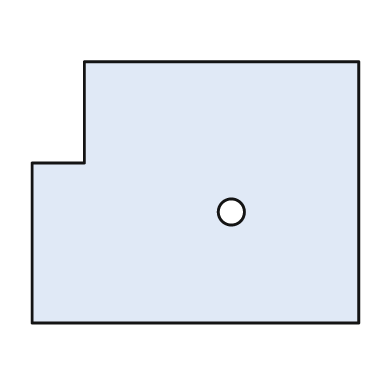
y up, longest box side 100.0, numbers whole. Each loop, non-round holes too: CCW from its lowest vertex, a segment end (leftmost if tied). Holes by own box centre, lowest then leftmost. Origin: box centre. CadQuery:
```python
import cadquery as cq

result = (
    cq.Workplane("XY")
    .moveTo(-50.0, -40.0)
    .lineTo(50.0, -40.0)
    .lineTo(50.0, 40.0)
    .lineTo(-34.0, 40.0)
    .lineTo(-34.0, 9.0)
    .lineTo(-50.0, 9.0)
    .close()
    .moveTo(11.0, -6.0)
    .circle(4.0)
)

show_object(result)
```